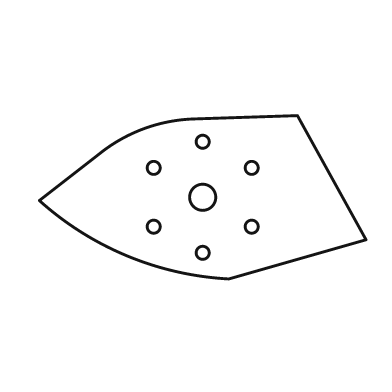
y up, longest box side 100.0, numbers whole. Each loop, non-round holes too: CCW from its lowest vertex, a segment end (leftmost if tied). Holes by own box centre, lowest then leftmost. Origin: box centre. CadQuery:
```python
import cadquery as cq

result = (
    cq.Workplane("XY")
    .moveTo(8.0, -25.0)
    .lineTo(50.0, -13.0)
    .lineTo(29.0, 25.0)
    .lineTo(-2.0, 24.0)
    .threePointArc((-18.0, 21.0), (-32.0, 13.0))
    .lineTo(-50.0, -1.0)
    .threePointArc((-23.0, -18.0), (8.0, -25.0))
    .close()
    .moveTo(0.0, -17.0)
    .circle(2.0)
    .moveTo(-15.0, -9.0)
    .circle(2.0)
    .moveTo(15.0, -9.0)
    .circle(2.0)
    .moveTo(0.0, 0.0)
    .circle(4.0)
    .moveTo(-15.0, 9.0)
    .circle(2.0)
    .moveTo(15.0, 9.0)
    .circle(2.0)
    .moveTo(0.0, 17.0)
    .circle(2.0)
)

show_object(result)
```